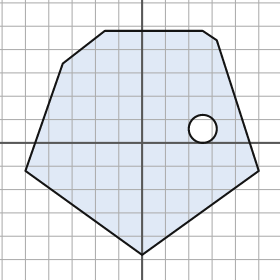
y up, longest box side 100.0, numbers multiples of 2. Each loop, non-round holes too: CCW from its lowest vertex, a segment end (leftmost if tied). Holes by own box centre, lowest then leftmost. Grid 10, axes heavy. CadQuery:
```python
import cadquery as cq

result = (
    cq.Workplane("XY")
    .moveTo(0.0, -48.0)
    .lineTo(50.0, -12.0)
    .lineTo(32.0, 44.0)
    .lineTo(26.0, 48.0)
    .lineTo(-16.0, 48.0)
    .lineTo(-34.0, 34.0)
    .lineTo(-50.0, -12.0)
    .close()
    .moveTo(26.0, 6.0)
    .circle(6.0)
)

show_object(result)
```